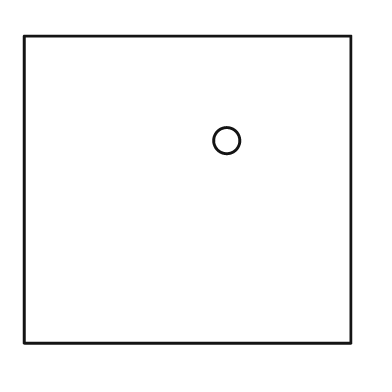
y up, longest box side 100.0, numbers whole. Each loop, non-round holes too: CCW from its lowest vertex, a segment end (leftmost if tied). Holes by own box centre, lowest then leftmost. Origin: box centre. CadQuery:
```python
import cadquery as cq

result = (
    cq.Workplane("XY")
    .moveTo(-50.0, -47.0)
    .lineTo(50.0, -47.0)
    .lineTo(50.0, 47.0)
    .lineTo(-50.0, 47.0)
    .close()
    .moveTo(12.0, 15.0)
    .circle(4.0)
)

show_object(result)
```